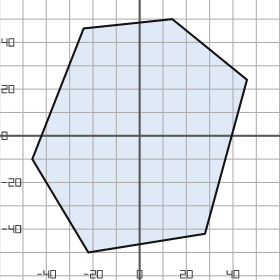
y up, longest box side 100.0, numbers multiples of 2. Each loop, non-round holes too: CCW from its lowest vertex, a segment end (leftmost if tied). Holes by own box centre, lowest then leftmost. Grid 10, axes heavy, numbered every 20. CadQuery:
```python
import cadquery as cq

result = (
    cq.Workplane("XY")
    .moveTo(-22.0, -50.0)
    .lineTo(28.0, -42.0)
    .lineTo(46.0, 24.0)
    .lineTo(14.0, 50.0)
    .lineTo(-24.0, 46.0)
    .lineTo(-46.0, -10.0)
    .close()
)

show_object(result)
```